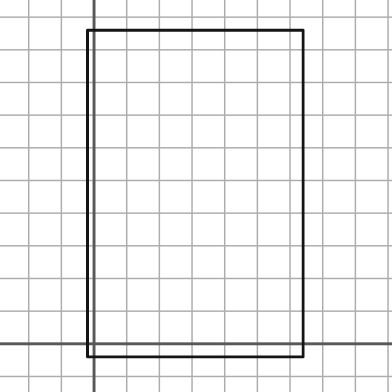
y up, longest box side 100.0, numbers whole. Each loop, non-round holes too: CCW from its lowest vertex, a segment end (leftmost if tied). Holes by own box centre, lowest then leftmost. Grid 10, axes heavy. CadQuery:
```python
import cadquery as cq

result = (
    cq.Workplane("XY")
    .moveTo(-2.0, -4.0)
    .lineTo(64.0, -4.0)
    .lineTo(64.0, 96.0)
    .lineTo(-2.0, 96.0)
    .close()
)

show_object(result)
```